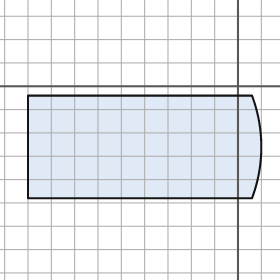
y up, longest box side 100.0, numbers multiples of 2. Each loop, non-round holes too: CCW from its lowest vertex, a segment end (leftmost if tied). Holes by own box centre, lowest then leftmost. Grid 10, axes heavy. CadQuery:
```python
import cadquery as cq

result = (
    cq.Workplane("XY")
    .moveTo(-90.0, -48.0)
    .lineTo(6.0, -48.0)
    .threePointArc((10.0, -26.0), (6.0, -4.0))
    .lineTo(-90.0, -4.0)
    .close()
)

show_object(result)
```